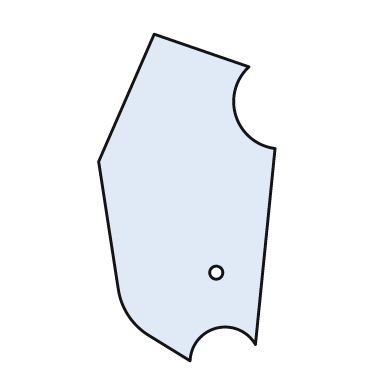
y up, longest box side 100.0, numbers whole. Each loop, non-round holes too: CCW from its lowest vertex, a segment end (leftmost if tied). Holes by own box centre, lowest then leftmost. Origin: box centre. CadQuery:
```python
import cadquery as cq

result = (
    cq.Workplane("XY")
    .moveTo(1.0, -50.0)
    .threePointArc((9.0, -40.0), (21.0, -45.0))
    .lineTo(27.0, 15.0)
    .threePointArc((15.0, 25.0), (19.0, 40.0))
    .lineTo(-10.0, 50.0)
    .lineTo(-27.0, 11.0)
    .lineTo(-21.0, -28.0)
    .threePointArc((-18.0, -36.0), (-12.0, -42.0))
    .close()
    .moveTo(9.0, -23.0)
    .circle(2.0)
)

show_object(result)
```